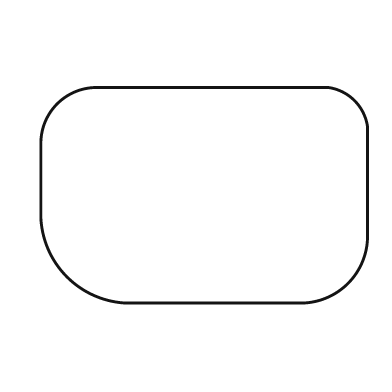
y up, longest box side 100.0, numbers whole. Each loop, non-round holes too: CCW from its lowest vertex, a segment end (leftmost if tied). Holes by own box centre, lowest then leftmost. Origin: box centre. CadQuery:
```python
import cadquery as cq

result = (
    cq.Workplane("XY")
    .moveTo(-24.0, -33.0)
    .lineTo(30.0, -33.0)
    .threePointArc((44.0, -27.0), (50.0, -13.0))
    .lineTo(50.0, 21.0)
    .threePointArc((46.0, 29.0), (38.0, 33.0))
    .lineTo(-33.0, 33.0)
    .threePointArc((-45.0, 28.0), (-50.0, 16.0))
    .lineTo(-50.0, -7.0)
    .threePointArc((-42.0, -25.0), (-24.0, -33.0))
    .close()
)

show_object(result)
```